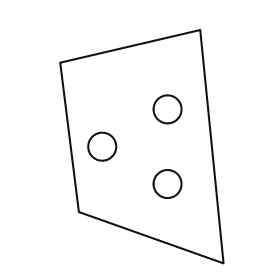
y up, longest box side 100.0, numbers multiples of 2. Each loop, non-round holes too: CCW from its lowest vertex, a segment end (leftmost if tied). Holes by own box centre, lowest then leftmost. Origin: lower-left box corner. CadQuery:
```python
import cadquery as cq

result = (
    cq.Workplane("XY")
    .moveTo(70.0, 0.0)
    .lineTo(60.0, 100.0)
    .lineTo(0.0, 86.0)
    .lineTo(8.0, 22.0)
    .close()
    .moveTo(46.0, 34.0)
    .circle(6.0)
    .moveTo(18.0, 50.0)
    .circle(6.0)
    .moveTo(46.0, 66.0)
    .circle(6.0)
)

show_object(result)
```